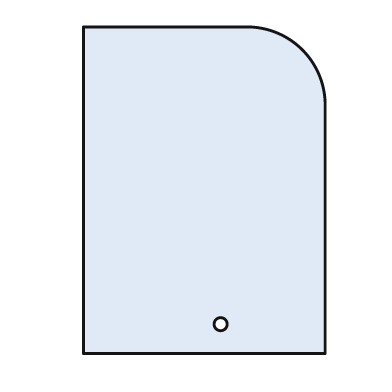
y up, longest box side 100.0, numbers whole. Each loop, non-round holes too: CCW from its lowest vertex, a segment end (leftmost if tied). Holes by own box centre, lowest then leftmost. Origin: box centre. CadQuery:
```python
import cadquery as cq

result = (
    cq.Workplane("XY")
    .moveTo(-37.0, -50.0)
    .lineTo(37.0, -50.0)
    .lineTo(37.0, 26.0)
    .threePointArc((30.0, 43.0), (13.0, 50.0))
    .lineTo(-37.0, 50.0)
    .close()
    .moveTo(5.0, -41.0)
    .circle(2.0)
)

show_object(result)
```